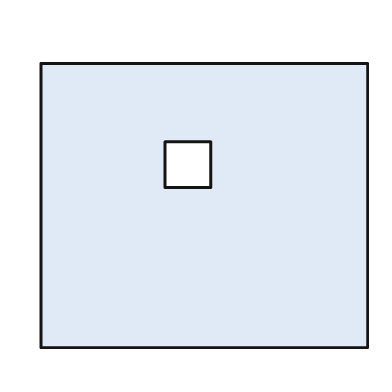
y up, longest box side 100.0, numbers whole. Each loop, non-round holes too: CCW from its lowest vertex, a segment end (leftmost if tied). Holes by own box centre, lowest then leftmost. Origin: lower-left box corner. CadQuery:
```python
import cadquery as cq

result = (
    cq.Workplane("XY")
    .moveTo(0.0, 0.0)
    .lineTo(100.0, 0.0)
    .lineTo(100.0, 87.0)
    .lineTo(0.0, 87.0)
    .close()
    .moveTo(38.0, 49.0)
    .lineTo(52.0, 49.0)
    .lineTo(52.0, 63.0)
    .lineTo(38.0, 63.0)
    .close()
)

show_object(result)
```